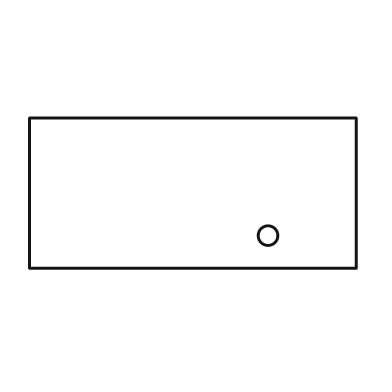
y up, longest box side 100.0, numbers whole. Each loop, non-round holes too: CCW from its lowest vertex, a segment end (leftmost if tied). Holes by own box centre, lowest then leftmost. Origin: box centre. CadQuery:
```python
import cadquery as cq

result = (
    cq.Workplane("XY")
    .moveTo(-50.0, -23.0)
    .lineTo(50.0, -23.0)
    .lineTo(50.0, 23.0)
    .lineTo(-50.0, 23.0)
    .close()
    .moveTo(23.0, -13.0)
    .circle(3.0)
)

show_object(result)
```